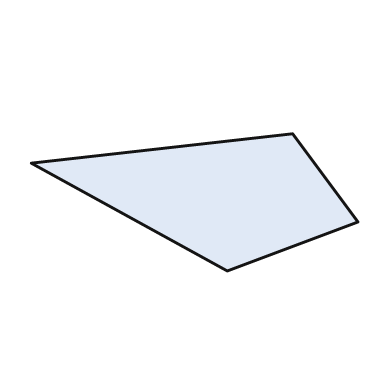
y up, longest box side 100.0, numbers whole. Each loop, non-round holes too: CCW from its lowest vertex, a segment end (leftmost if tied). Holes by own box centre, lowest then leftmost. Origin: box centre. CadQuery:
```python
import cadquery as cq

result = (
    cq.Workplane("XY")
    .moveTo(10.0, -21.0)
    .lineTo(50.0, -6.0)
    .lineTo(30.0, 21.0)
    .lineTo(-50.0, 12.0)
    .close()
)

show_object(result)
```